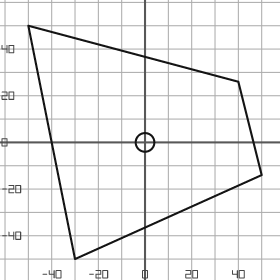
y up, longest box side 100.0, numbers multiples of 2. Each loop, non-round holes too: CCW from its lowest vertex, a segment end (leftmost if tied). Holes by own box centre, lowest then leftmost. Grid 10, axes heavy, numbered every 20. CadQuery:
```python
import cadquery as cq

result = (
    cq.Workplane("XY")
    .moveTo(-30.0, -50.0)
    .lineTo(50.0, -14.0)
    .lineTo(40.0, 26.0)
    .lineTo(-50.0, 50.0)
    .close()
    .moveTo(0.0, 0.0)
    .circle(4.0)
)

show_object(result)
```